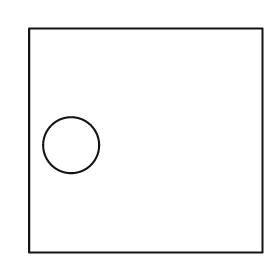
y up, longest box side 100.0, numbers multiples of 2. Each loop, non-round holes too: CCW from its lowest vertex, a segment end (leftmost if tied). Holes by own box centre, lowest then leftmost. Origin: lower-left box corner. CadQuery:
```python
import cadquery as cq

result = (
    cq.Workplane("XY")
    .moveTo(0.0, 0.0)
    .lineTo(100.0, 0.0)
    .lineTo(100.0, 96.0)
    .lineTo(0.0, 96.0)
    .close()
    .moveTo(18.0, 46.0)
    .circle(12.0)
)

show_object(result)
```